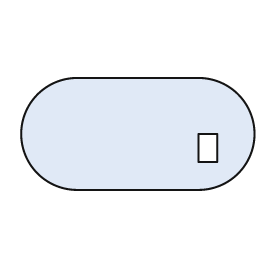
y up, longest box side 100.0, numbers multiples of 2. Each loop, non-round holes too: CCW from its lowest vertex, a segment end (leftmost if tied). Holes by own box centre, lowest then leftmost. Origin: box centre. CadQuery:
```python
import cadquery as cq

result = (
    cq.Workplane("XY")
    .moveTo(-26.0, -24.0)
    .lineTo(26.0, -24.0)
    .threePointArc((50.0, 0.0), (26.0, 24.0))
    .lineTo(-26.0, 24.0)
    .threePointArc((-50.0, 0.0), (-26.0, -24.0))
    .close()
    .moveTo(26.0, -12.0)
    .lineTo(34.0, -12.0)
    .lineTo(34.0, 0.0)
    .lineTo(26.0, 0.0)
    .close()
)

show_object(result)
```